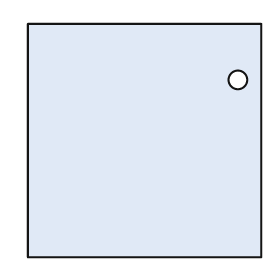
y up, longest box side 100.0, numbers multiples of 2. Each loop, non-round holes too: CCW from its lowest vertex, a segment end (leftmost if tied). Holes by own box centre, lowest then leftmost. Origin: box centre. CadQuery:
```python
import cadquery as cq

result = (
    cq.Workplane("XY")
    .moveTo(-50.0, -50.0)
    .lineTo(50.0, -50.0)
    .lineTo(50.0, 50.0)
    .lineTo(-50.0, 50.0)
    .close()
    .moveTo(40.0, 26.0)
    .circle(4.0)
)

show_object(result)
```